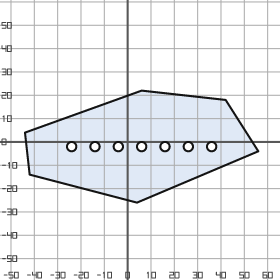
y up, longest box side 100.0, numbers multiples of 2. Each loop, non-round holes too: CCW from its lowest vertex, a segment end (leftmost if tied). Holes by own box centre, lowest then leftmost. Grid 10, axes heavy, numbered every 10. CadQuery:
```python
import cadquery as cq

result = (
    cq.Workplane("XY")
    .moveTo(4.0, -26.0)
    .lineTo(56.0, -4.0)
    .lineTo(42.0, 18.0)
    .lineTo(6.0, 22.0)
    .lineTo(-44.0, 4.0)
    .lineTo(-42.0, -14.0)
    .close()
    .moveTo(-24.0, -2.0)
    .circle(2.0)
    .moveTo(-14.0, -2.0)
    .circle(2.0)
    .moveTo(-4.0, -2.0)
    .circle(2.0)
    .moveTo(6.0, -2.0)
    .circle(2.0)
    .moveTo(16.0, -2.0)
    .circle(2.0)
    .moveTo(26.0, -2.0)
    .circle(2.0)
    .moveTo(36.0, -2.0)
    .circle(2.0)
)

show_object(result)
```